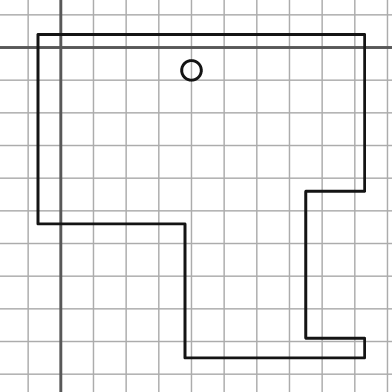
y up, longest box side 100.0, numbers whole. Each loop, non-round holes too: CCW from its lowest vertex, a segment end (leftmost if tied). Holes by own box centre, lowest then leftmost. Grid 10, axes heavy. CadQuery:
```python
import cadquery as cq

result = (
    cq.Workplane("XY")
    .moveTo(38.0, -95.0)
    .lineTo(93.0, -95.0)
    .lineTo(93.0, -89.0)
    .lineTo(75.0, -89.0)
    .lineTo(75.0, -44.0)
    .lineTo(93.0, -44.0)
    .lineTo(93.0, 4.0)
    .lineTo(-7.0, 4.0)
    .lineTo(-7.0, -54.0)
    .lineTo(38.0, -54.0)
    .close()
    .moveTo(40.0, -7.0)
    .circle(3.0)
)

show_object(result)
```